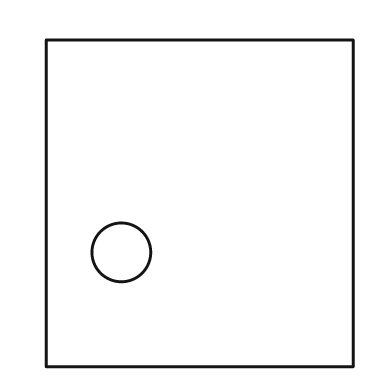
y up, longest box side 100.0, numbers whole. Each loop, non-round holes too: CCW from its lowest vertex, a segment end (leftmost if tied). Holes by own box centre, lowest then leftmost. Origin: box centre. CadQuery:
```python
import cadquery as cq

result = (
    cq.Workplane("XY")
    .moveTo(-47.0, -50.0)
    .lineTo(47.0, -50.0)
    .lineTo(47.0, 50.0)
    .lineTo(-47.0, 50.0)
    .close()
    .moveTo(-24.0, -15.0)
    .circle(9.0)
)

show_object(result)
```